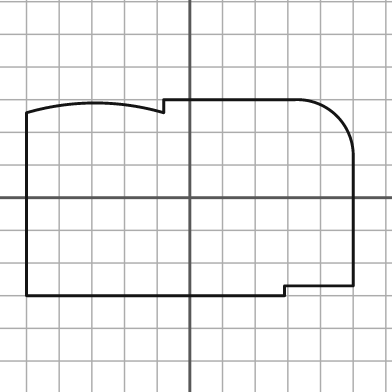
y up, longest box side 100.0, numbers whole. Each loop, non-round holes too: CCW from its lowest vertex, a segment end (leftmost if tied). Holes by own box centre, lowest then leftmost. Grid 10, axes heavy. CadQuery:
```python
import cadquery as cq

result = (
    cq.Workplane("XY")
    .moveTo(-50.0, -30.0)
    .lineTo(29.0, -30.0)
    .lineTo(29.0, -27.0)
    .lineTo(50.0, -27.0)
    .lineTo(50.0, 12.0)
    .threePointArc((45.0, 25.0), (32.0, 30.0))
    .lineTo(-8.0, 30.0)
    .lineTo(-8.0, 26.0)
    .threePointArc((-29.0, 29.0), (-50.0, 26.0))
    .close()
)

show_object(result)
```